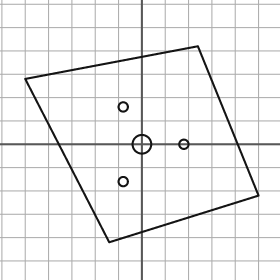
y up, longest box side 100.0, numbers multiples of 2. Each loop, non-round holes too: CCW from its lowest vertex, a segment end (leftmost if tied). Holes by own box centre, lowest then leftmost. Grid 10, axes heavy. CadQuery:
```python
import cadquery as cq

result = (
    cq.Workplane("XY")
    .moveTo(-14.0, -42.0)
    .lineTo(50.0, -22.0)
    .lineTo(24.0, 42.0)
    .lineTo(-50.0, 28.0)
    .close()
    .moveTo(-8.0, -16.0)
    .circle(2.0)
    .moveTo(0.0, 0.0)
    .circle(4.0)
    .moveTo(18.0, 0.0)
    .circle(2.0)
    .moveTo(-8.0, 16.0)
    .circle(2.0)
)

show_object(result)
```